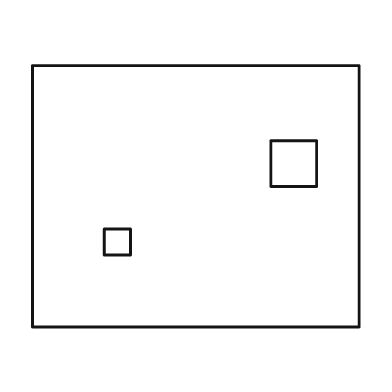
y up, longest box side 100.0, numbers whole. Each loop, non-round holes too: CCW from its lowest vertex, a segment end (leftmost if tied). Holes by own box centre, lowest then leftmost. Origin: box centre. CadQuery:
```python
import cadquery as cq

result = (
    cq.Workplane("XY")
    .moveTo(-50.0, -40.0)
    .lineTo(50.0, -40.0)
    .lineTo(50.0, 40.0)
    .lineTo(-50.0, 40.0)
    .close()
    .moveTo(-28.0, -18.0)
    .lineTo(-20.0, -18.0)
    .lineTo(-20.0, -10.0)
    .lineTo(-28.0, -10.0)
    .close()
    .moveTo(23.0, 3.0)
    .lineTo(37.0, 3.0)
    .lineTo(37.0, 17.0)
    .lineTo(23.0, 17.0)
    .close()
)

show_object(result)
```